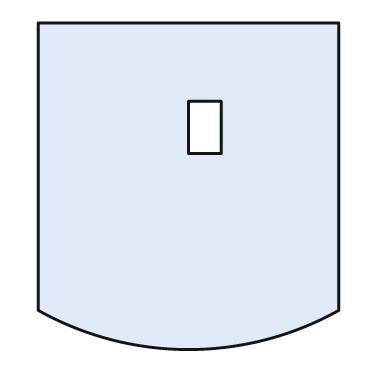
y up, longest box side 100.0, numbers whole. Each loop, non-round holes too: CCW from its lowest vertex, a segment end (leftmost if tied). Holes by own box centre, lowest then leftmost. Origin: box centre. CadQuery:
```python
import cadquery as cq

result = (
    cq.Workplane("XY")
    .moveTo(-46.0, -38.0)
    .threePointArc((0.0, -50.0), (46.0, -38.0))
    .lineTo(46.0, 50.0)
    .lineTo(-46.0, 50.0)
    .close()
    .moveTo(0.0, 10.0)
    .lineTo(10.0, 10.0)
    .lineTo(10.0, 26.0)
    .lineTo(0.0, 26.0)
    .close()
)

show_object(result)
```